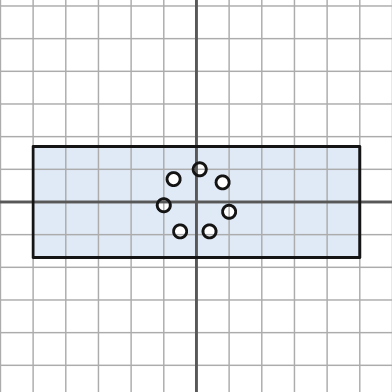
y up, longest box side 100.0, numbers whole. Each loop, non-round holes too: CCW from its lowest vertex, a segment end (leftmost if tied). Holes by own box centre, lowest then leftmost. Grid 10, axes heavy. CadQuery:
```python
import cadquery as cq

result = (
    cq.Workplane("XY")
    .moveTo(-50.0, -17.0)
    .lineTo(50.0, -17.0)
    .lineTo(50.0, 17.0)
    .lineTo(-50.0, 17.0)
    .close()
    .moveTo(-5.0, -9.0)
    .circle(2.0)
    .moveTo(4.0, -9.0)
    .circle(2.0)
    .moveTo(10.0, -3.0)
    .circle(2.0)
    .moveTo(-10.0, -1.0)
    .circle(2.0)
    .moveTo(8.0, 6.0)
    .circle(2.0)
    .moveTo(-7.0, 7.0)
    .circle(2.0)
    .moveTo(1.0, 10.0)
    .circle(2.0)
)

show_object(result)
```